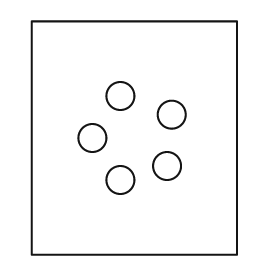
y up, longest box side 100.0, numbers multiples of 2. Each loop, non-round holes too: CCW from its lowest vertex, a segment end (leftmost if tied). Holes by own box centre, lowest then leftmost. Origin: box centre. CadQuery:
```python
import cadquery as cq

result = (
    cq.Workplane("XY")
    .moveTo(-44.0, -50.0)
    .lineTo(44.0, -50.0)
    .lineTo(44.0, 50.0)
    .lineTo(-44.0, 50.0)
    .close()
    .moveTo(-6.0, -18.0)
    .circle(6.0)
    .moveTo(14.0, -12.0)
    .circle(6.0)
    .moveTo(-18.0, 0.0)
    .circle(6.0)
    .moveTo(16.0, 10.0)
    .circle(6.0)
    .moveTo(-6.0, 18.0)
    .circle(6.0)
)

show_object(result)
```